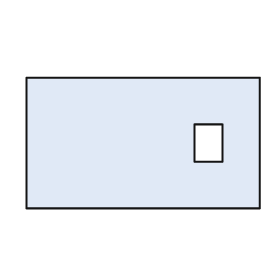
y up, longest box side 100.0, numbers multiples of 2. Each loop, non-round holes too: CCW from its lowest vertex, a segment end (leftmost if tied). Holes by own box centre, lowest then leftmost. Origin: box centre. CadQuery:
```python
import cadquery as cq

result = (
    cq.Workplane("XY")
    .moveTo(-50.0, -28.0)
    .lineTo(50.0, -28.0)
    .lineTo(50.0, 28.0)
    .lineTo(-50.0, 28.0)
    .close()
    .moveTo(22.0, -8.0)
    .lineTo(34.0, -8.0)
    .lineTo(34.0, 8.0)
    .lineTo(22.0, 8.0)
    .close()
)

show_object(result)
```